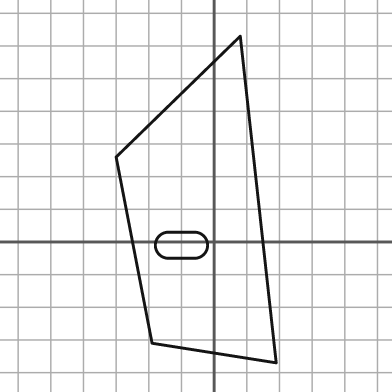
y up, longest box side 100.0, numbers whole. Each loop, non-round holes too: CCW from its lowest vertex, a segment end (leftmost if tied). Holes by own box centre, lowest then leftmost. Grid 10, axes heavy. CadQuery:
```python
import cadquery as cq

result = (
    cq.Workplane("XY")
    .moveTo(19.0, -37.0)
    .lineTo(8.0, 63.0)
    .lineTo(-30.0, 26.0)
    .lineTo(-19.0, -31.0)
    .close()
    .moveTo(-14.0, -5.0)
    .lineTo(-6.0, -5.0)
    .threePointArc((-2.0, -1.0), (-6.0, 3.0))
    .lineTo(-14.0, 3.0)
    .threePointArc((-18.0, -1.0), (-14.0, -5.0))
    .close()
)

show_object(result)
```